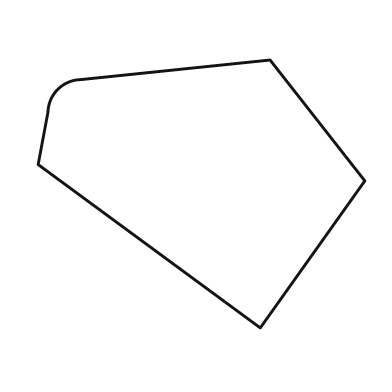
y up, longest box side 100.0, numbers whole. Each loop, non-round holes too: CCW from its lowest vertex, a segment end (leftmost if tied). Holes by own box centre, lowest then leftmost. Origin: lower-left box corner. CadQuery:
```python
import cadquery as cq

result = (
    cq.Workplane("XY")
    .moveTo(68.0, 0.0)
    .lineTo(100.0, 45.0)
    .lineTo(71.0, 82.0)
    .lineTo(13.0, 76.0)
    .threePointArc((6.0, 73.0), (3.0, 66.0))
    .lineTo(0.0, 50.0)
    .close()
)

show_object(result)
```